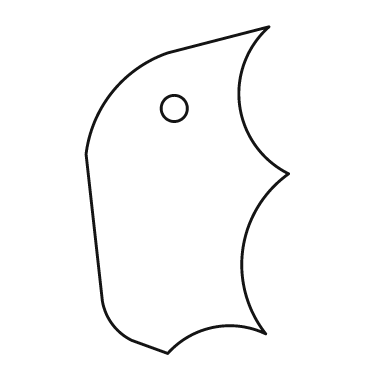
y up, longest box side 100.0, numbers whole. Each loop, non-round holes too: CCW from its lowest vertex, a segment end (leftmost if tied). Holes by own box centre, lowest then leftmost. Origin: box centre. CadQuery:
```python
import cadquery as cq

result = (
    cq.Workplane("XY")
    .moveTo(-6.0, -50.0)
    .threePointArc((8.0, -42.0), (24.0, -44.0))
    .threePointArc((17.0, -18.0), (31.0, 5.0))
    .threePointArc((16.0, 26.0), (25.0, 50.0))
    .lineTo(-6.0, 42.0)
    .threePointArc((-23.0, 30.0), (-31.0, 11.0))
    .lineTo(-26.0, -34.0)
    .threePointArc((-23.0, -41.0), (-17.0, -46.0))
    .close()
    .moveTo(-4.0, 25.0)
    .circle(4.0)
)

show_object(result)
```